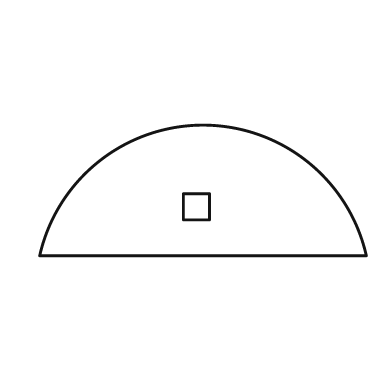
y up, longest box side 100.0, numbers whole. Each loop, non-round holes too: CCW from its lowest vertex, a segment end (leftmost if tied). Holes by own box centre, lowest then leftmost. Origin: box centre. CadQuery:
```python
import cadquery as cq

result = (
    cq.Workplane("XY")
    .moveTo(-50.0, -20.0)
    .lineTo(50.0, -20.0)
    .threePointArc((0.0, 20.0), (-50.0, -20.0))
    .close()
    .moveTo(-6.0, -9.0)
    .lineTo(2.0, -9.0)
    .lineTo(2.0, -1.0)
    .lineTo(-6.0, -1.0)
    .close()
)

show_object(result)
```